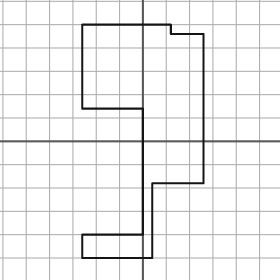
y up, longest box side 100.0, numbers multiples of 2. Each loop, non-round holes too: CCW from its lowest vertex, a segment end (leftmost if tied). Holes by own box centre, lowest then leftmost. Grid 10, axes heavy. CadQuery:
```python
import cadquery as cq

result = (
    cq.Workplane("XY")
    .moveTo(-26.0, -50.0)
    .lineTo(4.0, -50.0)
    .lineTo(4.0, -18.0)
    .lineTo(26.0, -18.0)
    .lineTo(26.0, 46.0)
    .lineTo(12.0, 46.0)
    .lineTo(12.0, 50.0)
    .lineTo(-26.0, 50.0)
    .lineTo(-26.0, 14.0)
    .lineTo(0.0, 14.0)
    .lineTo(0.0, -40.0)
    .lineTo(-26.0, -40.0)
    .close()
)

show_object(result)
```